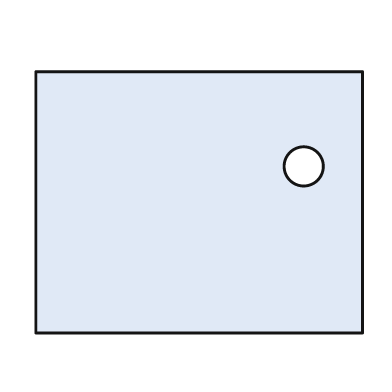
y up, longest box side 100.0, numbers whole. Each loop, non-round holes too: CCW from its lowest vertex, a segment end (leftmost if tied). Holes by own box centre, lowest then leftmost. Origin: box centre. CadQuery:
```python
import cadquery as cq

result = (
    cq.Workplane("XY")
    .moveTo(-50.0, -40.0)
    .lineTo(50.0, -40.0)
    .lineTo(50.0, 40.0)
    .lineTo(-50.0, 40.0)
    .close()
    .moveTo(32.0, 11.0)
    .circle(6.0)
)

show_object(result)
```